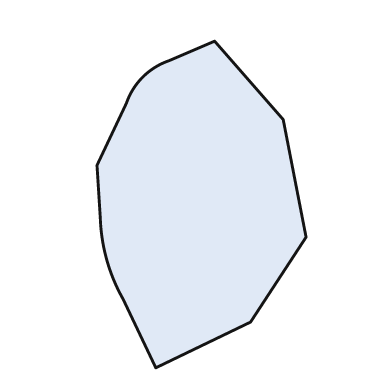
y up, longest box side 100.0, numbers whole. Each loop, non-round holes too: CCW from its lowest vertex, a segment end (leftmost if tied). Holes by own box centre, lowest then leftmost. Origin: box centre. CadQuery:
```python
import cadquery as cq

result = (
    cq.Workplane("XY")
    .moveTo(-14.0, -50.0)
    .lineTo(15.0, -36.0)
    .lineTo(32.0, -10.0)
    .lineTo(25.0, 26.0)
    .lineTo(4.0, 50.0)
    .lineTo(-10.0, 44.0)
    .threePointArc((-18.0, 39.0), (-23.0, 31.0))
    .lineTo(-32.0, 12.0)
    .lineTo(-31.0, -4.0)
    .threePointArc((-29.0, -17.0), (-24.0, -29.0))
    .close()
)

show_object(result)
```